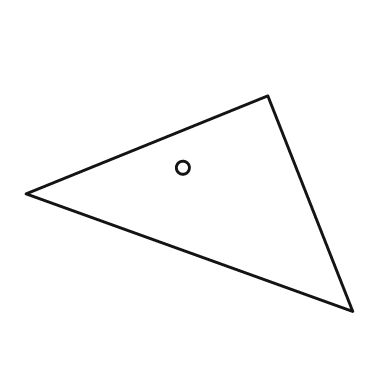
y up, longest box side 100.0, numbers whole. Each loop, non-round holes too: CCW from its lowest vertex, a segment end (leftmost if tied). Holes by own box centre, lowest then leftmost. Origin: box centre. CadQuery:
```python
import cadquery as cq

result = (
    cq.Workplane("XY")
    .moveTo(50.0, -33.0)
    .lineTo(24.0, 33.0)
    .lineTo(-50.0, 3.0)
    .close()
    .moveTo(-2.0, 11.0)
    .circle(2.0)
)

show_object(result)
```